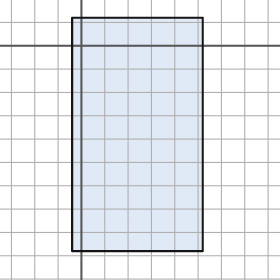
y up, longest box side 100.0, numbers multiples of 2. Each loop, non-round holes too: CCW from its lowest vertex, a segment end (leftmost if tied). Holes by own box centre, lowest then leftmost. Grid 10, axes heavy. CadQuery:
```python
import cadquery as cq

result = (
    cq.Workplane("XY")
    .moveTo(-4.0, -88.0)
    .lineTo(52.0, -88.0)
    .lineTo(52.0, 12.0)
    .lineTo(-4.0, 12.0)
    .close()
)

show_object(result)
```